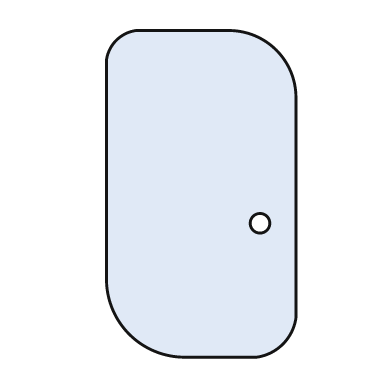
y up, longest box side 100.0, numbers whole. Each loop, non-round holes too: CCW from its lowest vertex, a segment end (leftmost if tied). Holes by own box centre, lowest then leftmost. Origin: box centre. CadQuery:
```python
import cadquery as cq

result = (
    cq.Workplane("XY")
    .moveTo(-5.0, -50.0)
    .lineTo(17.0, -50.0)
    .threePointArc((25.0, -46.0), (29.0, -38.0))
    .lineTo(29.0, 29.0)
    .threePointArc((23.0, 44.0), (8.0, 50.0))
    .lineTo(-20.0, 50.0)
    .threePointArc((-26.0, 47.0), (-29.0, 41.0))
    .lineTo(-29.0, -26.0)
    .threePointArc((-22.0, -43.0), (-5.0, -50.0))
    .close()
    .moveTo(18.0, -9.0)
    .circle(3.0)
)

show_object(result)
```